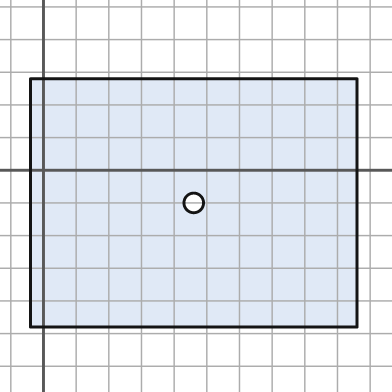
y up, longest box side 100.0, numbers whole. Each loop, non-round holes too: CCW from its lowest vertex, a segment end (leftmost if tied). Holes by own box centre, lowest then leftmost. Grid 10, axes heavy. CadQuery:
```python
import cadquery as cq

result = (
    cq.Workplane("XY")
    .moveTo(-4.0, -48.0)
    .lineTo(96.0, -48.0)
    .lineTo(96.0, 28.0)
    .lineTo(-4.0, 28.0)
    .close()
    .moveTo(46.0, -10.0)
    .circle(3.0)
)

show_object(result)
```